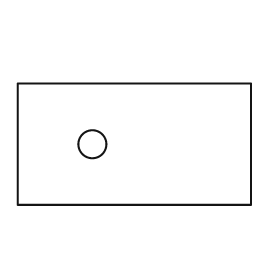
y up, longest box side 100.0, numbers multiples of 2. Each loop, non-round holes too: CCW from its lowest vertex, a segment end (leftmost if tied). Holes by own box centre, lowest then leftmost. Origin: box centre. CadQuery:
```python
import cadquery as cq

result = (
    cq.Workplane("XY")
    .moveTo(-50.0, -26.0)
    .lineTo(50.0, -26.0)
    .lineTo(50.0, 26.0)
    .lineTo(-50.0, 26.0)
    .close()
    .moveTo(-18.0, 0.0)
    .circle(6.0)
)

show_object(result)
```